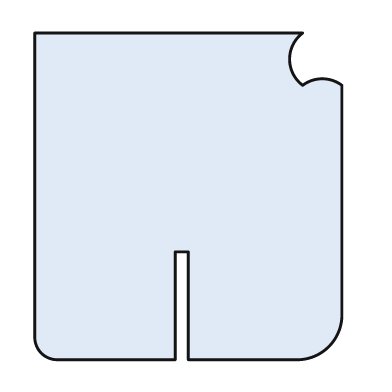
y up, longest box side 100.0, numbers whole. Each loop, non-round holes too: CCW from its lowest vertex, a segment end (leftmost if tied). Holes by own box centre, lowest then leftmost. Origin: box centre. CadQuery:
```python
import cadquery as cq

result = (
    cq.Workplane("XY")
    .moveTo(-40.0, -50.0)
    .lineTo(-4.0, -50.0)
    .lineTo(-4.0, -17.0)
    .lineTo(0.0, -17.0)
    .lineTo(0.0, -50.0)
    .lineTo(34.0, -50.0)
    .threePointArc((43.0, -46.0), (47.0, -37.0))
    .lineTo(47.0, 34.0)
    .threePointArc((41.0, 36.0), (35.0, 34.0))
    .threePointArc((31.0, 42.0), (35.0, 50.0))
    .lineTo(-47.0, 50.0)
    .lineTo(-47.0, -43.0)
    .threePointArc((-45.0, -48.0), (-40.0, -50.0))
    .close()
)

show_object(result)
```